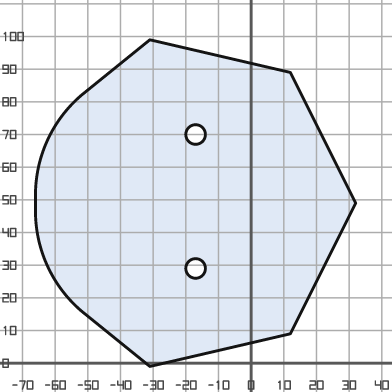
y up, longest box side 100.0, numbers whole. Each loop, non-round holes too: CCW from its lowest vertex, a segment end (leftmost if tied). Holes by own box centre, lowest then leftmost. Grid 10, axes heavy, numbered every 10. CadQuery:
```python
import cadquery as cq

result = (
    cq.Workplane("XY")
    .moveTo(-31.0, -1.0)
    .lineTo(12.0, 9.0)
    .lineTo(32.0, 49.0)
    .lineTo(12.0, 89.0)
    .lineTo(-31.0, 99.0)
    .lineTo(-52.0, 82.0)
    .threePointArc((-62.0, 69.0), (-66.0, 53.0))
    .lineTo(-66.0, 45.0)
    .threePointArc((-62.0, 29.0), (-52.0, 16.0))
    .close()
    .moveTo(-17.0, 29.0)
    .circle(3.0)
    .moveTo(-17.0, 70.0)
    .circle(3.0)
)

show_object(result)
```